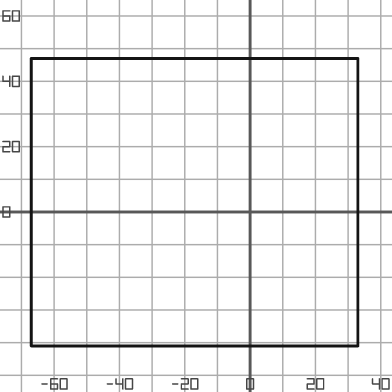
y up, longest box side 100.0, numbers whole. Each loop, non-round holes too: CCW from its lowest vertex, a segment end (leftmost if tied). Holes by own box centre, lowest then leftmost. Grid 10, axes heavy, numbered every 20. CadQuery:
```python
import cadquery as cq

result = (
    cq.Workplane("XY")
    .moveTo(-67.0, -41.0)
    .lineTo(33.0, -41.0)
    .lineTo(33.0, 47.0)
    .lineTo(-67.0, 47.0)
    .close()
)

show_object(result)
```